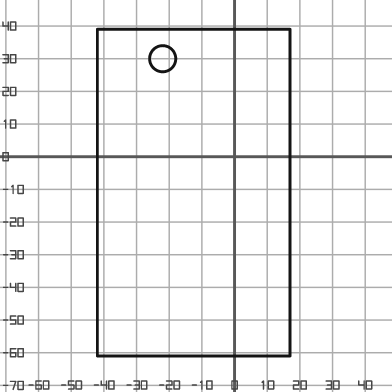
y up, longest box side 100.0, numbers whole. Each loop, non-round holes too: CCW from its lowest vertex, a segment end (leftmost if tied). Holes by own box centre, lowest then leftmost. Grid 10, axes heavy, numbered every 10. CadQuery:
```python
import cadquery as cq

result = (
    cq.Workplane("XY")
    .moveTo(-42.0, -61.0)
    .lineTo(17.0, -61.0)
    .lineTo(17.0, 39.0)
    .lineTo(-42.0, 39.0)
    .close()
    .moveTo(-22.0, 30.0)
    .circle(4.0)
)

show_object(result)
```